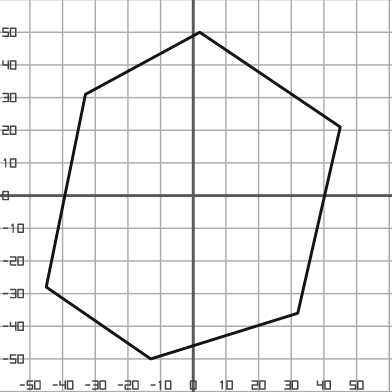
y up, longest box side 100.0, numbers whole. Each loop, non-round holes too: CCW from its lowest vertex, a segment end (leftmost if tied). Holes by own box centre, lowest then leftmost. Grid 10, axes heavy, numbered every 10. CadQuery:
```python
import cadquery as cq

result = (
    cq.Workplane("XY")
    .moveTo(-13.0, -50.0)
    .lineTo(32.0, -36.0)
    .lineTo(45.0, 21.0)
    .lineTo(2.0, 50.0)
    .lineTo(-33.0, 31.0)
    .lineTo(-45.0, -28.0)
    .close()
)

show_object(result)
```